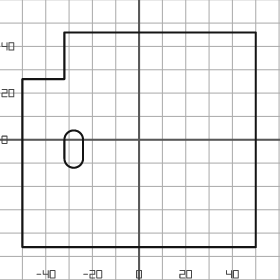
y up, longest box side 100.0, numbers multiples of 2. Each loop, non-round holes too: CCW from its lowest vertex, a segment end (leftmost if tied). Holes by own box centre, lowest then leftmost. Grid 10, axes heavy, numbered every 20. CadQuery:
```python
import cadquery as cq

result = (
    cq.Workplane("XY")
    .moveTo(-50.0, -46.0)
    .lineTo(50.0, -46.0)
    .lineTo(50.0, 46.0)
    .lineTo(-32.0, 46.0)
    .lineTo(-32.0, 26.0)
    .lineTo(-50.0, 26.0)
    .close()
    .moveTo(-32.0, -8.0)
    .threePointArc((-28.0, -12.0), (-24.0, -8.0))
    .lineTo(-24.0, 0.0)
    .threePointArc((-28.0, 4.0), (-32.0, 0.0))
    .close()
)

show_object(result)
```